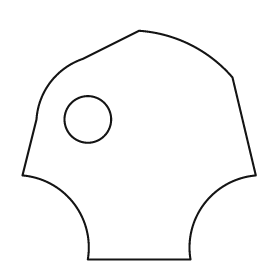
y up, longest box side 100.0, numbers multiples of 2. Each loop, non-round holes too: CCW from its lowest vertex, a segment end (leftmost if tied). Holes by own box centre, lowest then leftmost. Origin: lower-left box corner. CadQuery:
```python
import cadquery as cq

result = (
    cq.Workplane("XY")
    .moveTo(28.0, 0.0)
    .lineTo(72.0, 0.0)
    .threePointArc((78.0, 24.0), (100.0, 36.0))
    .lineTo(90.0, 78.0)
    .threePointArc((72.0, 92.0), (50.0, 98.0))
    .lineTo(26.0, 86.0)
    .threePointArc((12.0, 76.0), (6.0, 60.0))
    .lineTo(0.0, 36.0)
    .threePointArc((22.0, 24.0), (28.0, 0.0))
    .close()
    .moveTo(28.0, 60.0)
    .circle(10.0)
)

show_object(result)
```